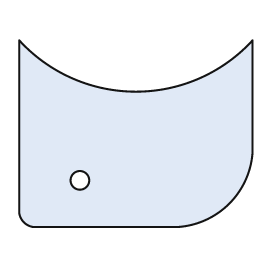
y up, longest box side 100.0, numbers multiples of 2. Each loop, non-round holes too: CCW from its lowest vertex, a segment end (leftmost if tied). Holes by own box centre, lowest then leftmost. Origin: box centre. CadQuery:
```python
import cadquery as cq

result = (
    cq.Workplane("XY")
    .moveTo(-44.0, -40.0)
    .lineTo(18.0, -40.0)
    .threePointArc((40.0, -30.0), (50.0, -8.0))
    .lineTo(50.0, 40.0)
    .threePointArc((0.0, 18.0), (-50.0, 40.0))
    .lineTo(-50.0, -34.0)
    .threePointArc((-48.0, -38.0), (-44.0, -40.0))
    .close()
    .moveTo(-24.0, -20.0)
    .circle(4.0)
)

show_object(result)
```